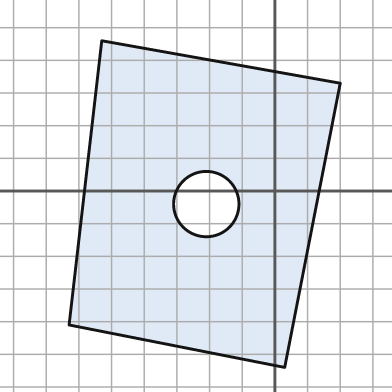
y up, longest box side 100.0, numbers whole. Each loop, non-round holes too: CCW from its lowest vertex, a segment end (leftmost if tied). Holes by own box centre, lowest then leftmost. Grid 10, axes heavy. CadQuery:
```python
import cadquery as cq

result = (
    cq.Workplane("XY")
    .moveTo(3.0, -54.0)
    .lineTo(20.0, 33.0)
    .lineTo(-53.0, 46.0)
    .lineTo(-63.0, -41.0)
    .close()
    .moveTo(-21.0, -4.0)
    .circle(10.0)
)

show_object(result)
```